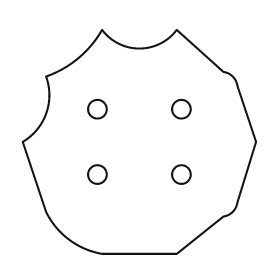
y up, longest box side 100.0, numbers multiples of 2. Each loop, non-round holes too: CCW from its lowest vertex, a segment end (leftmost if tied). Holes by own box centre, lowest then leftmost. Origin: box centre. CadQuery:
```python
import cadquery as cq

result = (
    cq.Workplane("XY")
    .moveTo(-16.0, -48.0)
    .lineTo(16.0, -48.0)
    .lineTo(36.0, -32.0)
    .threePointArc((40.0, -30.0), (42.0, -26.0))
    .lineTo(50.0, 0.0)
    .lineTo(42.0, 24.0)
    .threePointArc((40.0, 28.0), (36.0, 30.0))
    .lineTo(16.0, 48.0)
    .threePointArc((0.0, 40.0), (-16.0, 48.0))
    .threePointArc((-26.0, 36.0), (-40.0, 28.0))
    .threePointArc((-40.0, 12.0), (-50.0, 0.0))
    .lineTo(-40.0, -30.0)
    .threePointArc((-30.0, -42.0), (-16.0, -48.0))
    .close()
    .moveTo(-18.0, -14.0)
    .circle(4.0)
    .moveTo(18.0, -14.0)
    .circle(4.0)
    .moveTo(-18.0, 14.0)
    .circle(4.0)
    .moveTo(18.0, 14.0)
    .circle(4.0)
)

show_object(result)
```